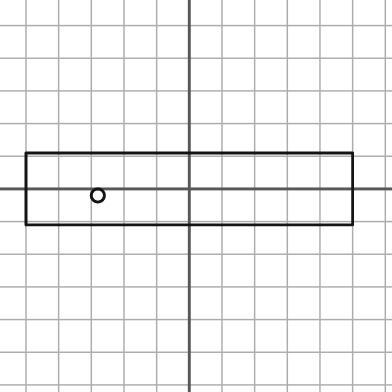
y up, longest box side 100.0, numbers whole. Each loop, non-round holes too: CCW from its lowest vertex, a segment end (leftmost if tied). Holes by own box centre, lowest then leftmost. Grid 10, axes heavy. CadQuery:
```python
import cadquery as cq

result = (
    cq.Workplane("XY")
    .moveTo(-50.0, -11.0)
    .lineTo(50.0, -11.0)
    .lineTo(50.0, 11.0)
    .lineTo(-50.0, 11.0)
    .close()
    .moveTo(-28.0, -2.0)
    .circle(2.0)
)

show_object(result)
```